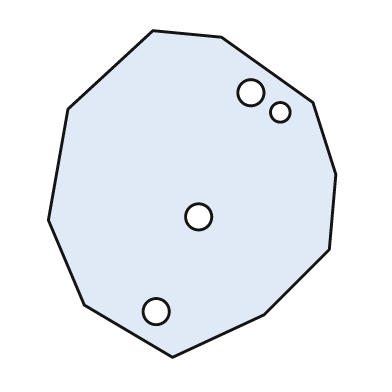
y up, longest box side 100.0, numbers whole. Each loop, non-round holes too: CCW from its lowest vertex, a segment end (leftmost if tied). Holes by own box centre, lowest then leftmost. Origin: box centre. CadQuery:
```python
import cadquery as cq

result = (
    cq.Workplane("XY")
    .moveTo(-6.0, -50.0)
    .lineTo(22.0, -37.0)
    .lineTo(42.0, -17.0)
    .lineTo(44.0, 6.0)
    .lineTo(37.0, 28.0)
    .lineTo(9.0, 48.0)
    .lineTo(-12.0, 50.0)
    .lineTo(-38.0, 26.0)
    .lineTo(-44.0, -8.0)
    .lineTo(-33.0, -34.0)
    .close()
    .moveTo(-11.0, -36.0)
    .circle(4.0)
    .moveTo(2.0, -7.0)
    .circle(4.0)
    .moveTo(27.0, 25.0)
    .circle(3.0)
    .moveTo(18.0, 31.0)
    .circle(4.0)
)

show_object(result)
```